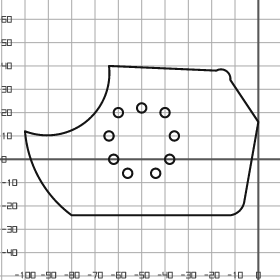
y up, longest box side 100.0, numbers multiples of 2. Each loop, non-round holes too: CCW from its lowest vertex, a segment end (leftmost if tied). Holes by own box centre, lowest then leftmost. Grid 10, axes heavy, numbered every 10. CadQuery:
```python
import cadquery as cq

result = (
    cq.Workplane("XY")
    .moveTo(-80.0, -24.0)
    .lineTo(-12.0, -24.0)
    .threePointArc((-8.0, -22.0), (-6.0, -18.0))
    .lineTo(0.0, 16.0)
    .lineTo(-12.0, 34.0)
    .threePointArc((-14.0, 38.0), (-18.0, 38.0))
    .lineTo(-64.0, 40.0)
    .threePointArc((-74.0, 16.0), (-100.0, 12.0))
    .threePointArc((-94.0, -8.0), (-80.0, -24.0))
    .close()
    .moveTo(-56.0, -6.0)
    .circle(2.0)
    .moveTo(-44.0, -6.0)
    .circle(2.0)
    .moveTo(-62.0, 0.0)
    .circle(2.0)
    .moveTo(-38.0, 0.0)
    .circle(2.0)
    .moveTo(-64.0, 10.0)
    .circle(2.0)
    .moveTo(-36.0, 10.0)
    .circle(2.0)
    .moveTo(-60.0, 20.0)
    .circle(2.0)
    .moveTo(-40.0, 20.0)
    .circle(2.0)
    .moveTo(-50.0, 22.0)
    .circle(2.0)
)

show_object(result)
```